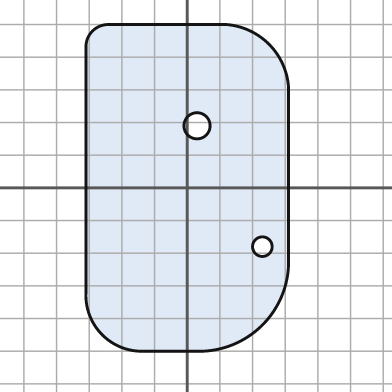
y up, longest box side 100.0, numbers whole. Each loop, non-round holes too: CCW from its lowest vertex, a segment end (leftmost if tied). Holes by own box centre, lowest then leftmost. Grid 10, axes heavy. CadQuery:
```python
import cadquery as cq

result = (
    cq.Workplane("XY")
    .moveTo(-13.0, -50.0)
    .lineTo(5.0, -50.0)
    .threePointArc((23.0, -42.0), (31.0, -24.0))
    .lineTo(31.0, 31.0)
    .threePointArc((25.0, 44.0), (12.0, 50.0))
    .lineTo(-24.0, 50.0)
    .threePointArc((-29.0, 48.0), (-31.0, 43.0))
    .lineTo(-31.0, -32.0)
    .threePointArc((-26.0, -45.0), (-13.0, -50.0))
    .close()
    .moveTo(23.0, -18.0)
    .circle(3.0)
    .moveTo(3.0, 19.0)
    .circle(4.0)
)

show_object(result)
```